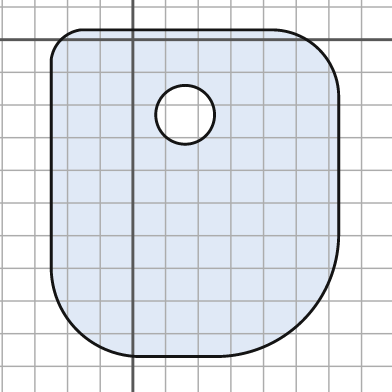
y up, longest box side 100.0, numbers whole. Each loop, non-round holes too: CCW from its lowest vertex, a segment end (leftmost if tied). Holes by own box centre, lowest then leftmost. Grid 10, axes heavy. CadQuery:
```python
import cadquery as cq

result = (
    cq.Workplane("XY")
    .moveTo(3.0, -97.0)
    .lineTo(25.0, -97.0)
    .threePointArc((52.0, -86.0), (63.0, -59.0))
    .lineTo(63.0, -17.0)
    .threePointArc((57.0, -3.0), (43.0, 3.0))
    .lineTo(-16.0, 3.0)
    .threePointArc((-22.0, 0.0), (-25.0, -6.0))
    .lineTo(-25.0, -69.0)
    .threePointArc((-17.0, -89.0), (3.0, -97.0))
    .close()
    .moveTo(16.0, -23.0)
    .circle(9.0)
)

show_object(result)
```